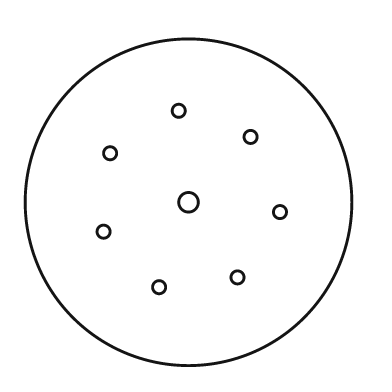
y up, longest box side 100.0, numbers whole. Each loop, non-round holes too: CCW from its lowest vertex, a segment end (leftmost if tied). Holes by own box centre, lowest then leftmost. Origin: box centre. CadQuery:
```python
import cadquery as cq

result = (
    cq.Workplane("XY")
    .moveTo(0.0, 0.0)
    .circle(50.0)
    .moveTo(-9.0, -26.0)
    .circle(2.0)
    .moveTo(15.0, -23.0)
    .circle(2.0)
    .moveTo(-26.0, -9.0)
    .circle(2.0)
    .moveTo(28.0, -3.0)
    .circle(2.0)
    .moveTo(0.0, 0.0)
    .circle(3.0)
    .moveTo(-24.0, 15.0)
    .circle(2.0)
    .moveTo(19.0, 20.0)
    .circle(2.0)
    .moveTo(-3.0, 28.0)
    .circle(2.0)
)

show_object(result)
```